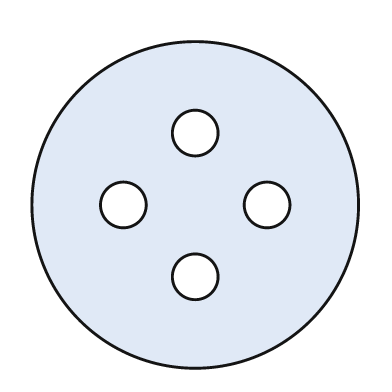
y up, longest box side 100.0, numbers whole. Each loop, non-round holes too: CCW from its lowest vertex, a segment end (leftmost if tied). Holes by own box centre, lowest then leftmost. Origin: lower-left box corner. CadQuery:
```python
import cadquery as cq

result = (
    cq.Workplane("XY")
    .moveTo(50.0, 50.0)
    .circle(50.0)
    .moveTo(50.0, 28.0)
    .circle(7.0)
    .moveTo(28.0, 50.0)
    .circle(7.0)
    .moveTo(72.0, 50.0)
    .circle(7.0)
    .moveTo(50.0, 72.0)
    .circle(7.0)
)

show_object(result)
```